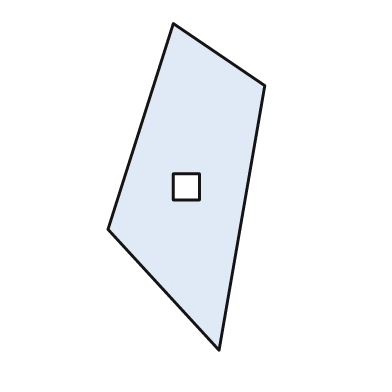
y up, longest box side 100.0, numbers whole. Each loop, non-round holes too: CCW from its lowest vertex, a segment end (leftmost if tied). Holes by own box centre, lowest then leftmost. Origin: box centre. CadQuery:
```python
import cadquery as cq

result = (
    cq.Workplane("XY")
    .moveTo(10.0, -50.0)
    .lineTo(24.0, 31.0)
    .lineTo(-4.0, 50.0)
    .lineTo(-24.0, -13.0)
    .close()
    .moveTo(-4.0, -4.0)
    .lineTo(4.0, -4.0)
    .lineTo(4.0, 4.0)
    .lineTo(-4.0, 4.0)
    .close()
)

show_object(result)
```